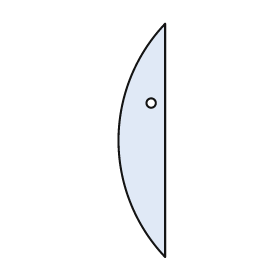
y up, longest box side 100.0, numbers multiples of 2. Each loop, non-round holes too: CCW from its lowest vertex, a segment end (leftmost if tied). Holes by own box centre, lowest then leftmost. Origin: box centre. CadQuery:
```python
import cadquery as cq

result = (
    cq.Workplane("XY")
    .moveTo(10.0, -50.0)
    .lineTo(10.0, 50.0)
    .threePointArc((-10.0, 0.0), (10.0, -50.0))
    .close()
    .moveTo(4.0, 16.0)
    .circle(2.0)
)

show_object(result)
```